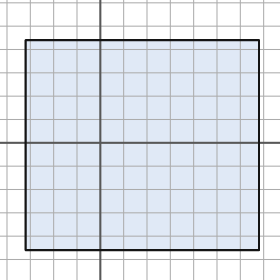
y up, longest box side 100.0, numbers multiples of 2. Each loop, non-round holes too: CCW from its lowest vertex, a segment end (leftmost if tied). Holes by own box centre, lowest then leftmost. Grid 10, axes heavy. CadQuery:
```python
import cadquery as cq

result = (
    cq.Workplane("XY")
    .moveTo(-32.0, -46.0)
    .lineTo(68.0, -46.0)
    .lineTo(68.0, 44.0)
    .lineTo(-32.0, 44.0)
    .close()
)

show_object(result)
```